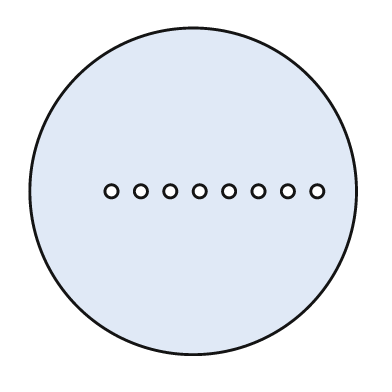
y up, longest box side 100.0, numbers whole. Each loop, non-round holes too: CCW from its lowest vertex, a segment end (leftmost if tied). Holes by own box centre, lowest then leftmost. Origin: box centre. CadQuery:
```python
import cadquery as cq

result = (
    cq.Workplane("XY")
    .moveTo(0.0, 0.0)
    .circle(50.0)
    .moveTo(-25.0, 0.0)
    .circle(2.0)
    .moveTo(-16.0, 0.0)
    .circle(2.0)
    .moveTo(-7.0, 0.0)
    .circle(2.0)
    .moveTo(2.0, 0.0)
    .circle(2.0)
    .moveTo(11.0, 0.0)
    .circle(2.0)
    .moveTo(20.0, 0.0)
    .circle(2.0)
    .moveTo(29.0, 0.0)
    .circle(2.0)
    .moveTo(38.0, 0.0)
    .circle(2.0)
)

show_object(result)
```